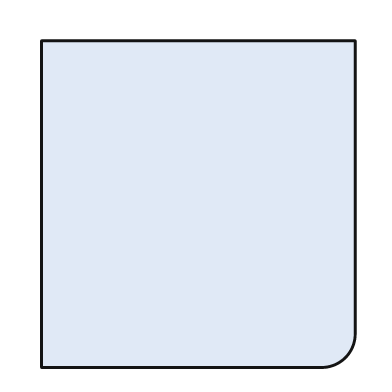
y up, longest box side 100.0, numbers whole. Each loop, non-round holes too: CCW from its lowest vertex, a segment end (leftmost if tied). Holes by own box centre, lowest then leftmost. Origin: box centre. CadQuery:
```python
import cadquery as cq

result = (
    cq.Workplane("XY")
    .moveTo(-48.0, -50.0)
    .lineTo(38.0, -50.0)
    .threePointArc((45.0, -47.0), (48.0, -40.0))
    .lineTo(48.0, 50.0)
    .lineTo(-48.0, 50.0)
    .close()
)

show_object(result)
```